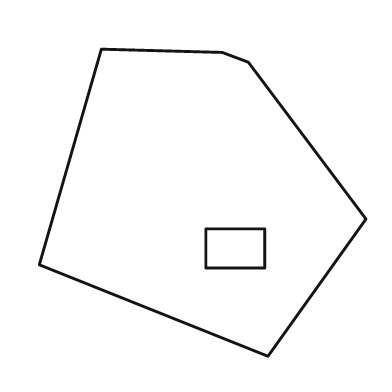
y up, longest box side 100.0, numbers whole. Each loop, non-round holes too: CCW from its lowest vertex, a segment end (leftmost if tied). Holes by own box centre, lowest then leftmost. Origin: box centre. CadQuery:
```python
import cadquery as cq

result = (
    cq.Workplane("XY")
    .moveTo(20.0, -47.0)
    .lineTo(50.0, -5.0)
    .lineTo(14.0, 43.0)
    .lineTo(6.0, 46.0)
    .lineTo(-31.0, 47.0)
    .lineTo(-50.0, -19.0)
    .close()
    .moveTo(1.0, -20.0)
    .lineTo(19.0, -20.0)
    .lineTo(19.0, -8.0)
    .lineTo(1.0, -8.0)
    .close()
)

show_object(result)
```